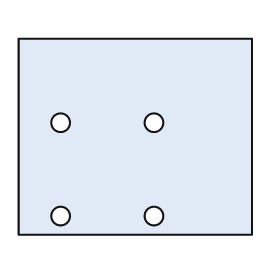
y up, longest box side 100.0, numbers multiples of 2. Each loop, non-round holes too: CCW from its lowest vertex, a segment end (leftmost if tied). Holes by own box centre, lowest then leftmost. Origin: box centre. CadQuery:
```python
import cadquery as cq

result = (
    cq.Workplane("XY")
    .moveTo(-50.0, -42.0)
    .lineTo(50.0, -42.0)
    .lineTo(50.0, 42.0)
    .lineTo(-50.0, 42.0)
    .close()
    .moveTo(-32.0, -34.0)
    .circle(4.0)
    .moveTo(8.0, -34.0)
    .circle(4.0)
    .moveTo(-32.0, 6.0)
    .circle(4.0)
    .moveTo(8.0, 6.0)
    .circle(4.0)
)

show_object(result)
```